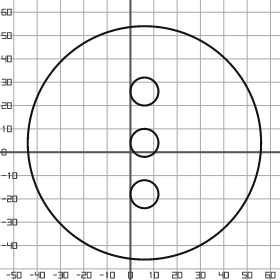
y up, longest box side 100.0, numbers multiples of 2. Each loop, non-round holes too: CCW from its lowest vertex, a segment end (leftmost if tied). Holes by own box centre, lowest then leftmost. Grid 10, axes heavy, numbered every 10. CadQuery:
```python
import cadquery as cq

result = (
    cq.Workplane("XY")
    .moveTo(6.0, 4.0)
    .circle(50.0)
    .moveTo(6.0, -18.0)
    .circle(6.0)
    .moveTo(6.0, 4.0)
    .circle(6.0)
    .moveTo(6.0, 26.0)
    .circle(6.0)
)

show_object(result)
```